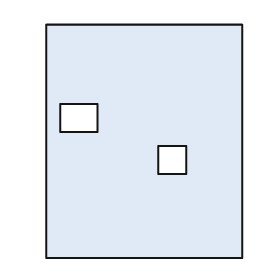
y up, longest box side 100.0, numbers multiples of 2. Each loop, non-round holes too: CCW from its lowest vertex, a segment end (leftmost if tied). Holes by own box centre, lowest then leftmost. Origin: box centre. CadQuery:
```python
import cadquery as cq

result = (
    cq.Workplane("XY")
    .moveTo(-42.0, -50.0)
    .lineTo(42.0, -50.0)
    .lineTo(42.0, 50.0)
    .lineTo(-42.0, 50.0)
    .close()
    .moveTo(6.0, -14.0)
    .lineTo(18.0, -14.0)
    .lineTo(18.0, -2.0)
    .lineTo(6.0, -2.0)
    .close()
    .moveTo(-36.0, 4.0)
    .lineTo(-20.0, 4.0)
    .lineTo(-20.0, 16.0)
    .lineTo(-36.0, 16.0)
    .close()
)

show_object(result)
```